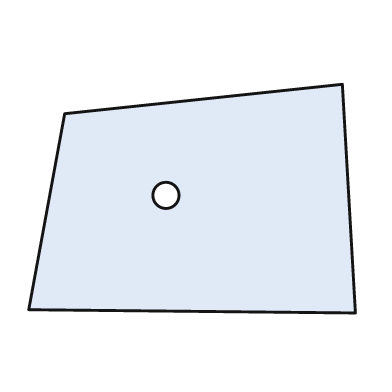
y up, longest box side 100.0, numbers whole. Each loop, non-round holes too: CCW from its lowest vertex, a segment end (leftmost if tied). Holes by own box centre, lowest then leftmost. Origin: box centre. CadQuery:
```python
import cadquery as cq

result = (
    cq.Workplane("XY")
    .moveTo(50.0, -35.0)
    .lineTo(46.0, 35.0)
    .lineTo(-39.0, 26.0)
    .lineTo(-50.0, -34.0)
    .close()
    .moveTo(-8.0, 1.0)
    .circle(4.0)
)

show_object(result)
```